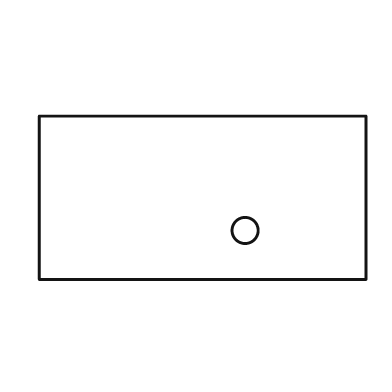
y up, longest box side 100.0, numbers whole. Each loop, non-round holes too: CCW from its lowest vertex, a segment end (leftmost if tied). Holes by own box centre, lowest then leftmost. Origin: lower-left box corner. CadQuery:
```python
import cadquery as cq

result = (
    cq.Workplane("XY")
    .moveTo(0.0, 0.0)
    .lineTo(100.0, 0.0)
    .lineTo(100.0, 50.0)
    .lineTo(0.0, 50.0)
    .close()
    .moveTo(63.0, 15.0)
    .circle(4.0)
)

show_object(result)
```